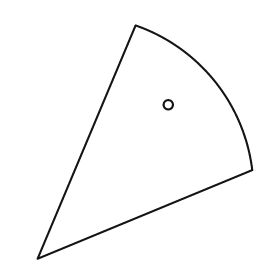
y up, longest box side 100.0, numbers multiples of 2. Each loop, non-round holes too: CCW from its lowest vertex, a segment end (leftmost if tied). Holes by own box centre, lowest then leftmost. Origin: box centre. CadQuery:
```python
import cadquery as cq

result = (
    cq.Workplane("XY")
    .moveTo(-46.0, -50.0)
    .lineTo(46.0, -12.0)
    .threePointArc((30.0, 26.0), (-4.0, 50.0))
    .close()
    .moveTo(10.0, 16.0)
    .circle(2.0)
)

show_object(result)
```